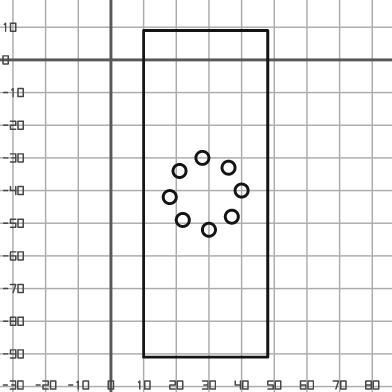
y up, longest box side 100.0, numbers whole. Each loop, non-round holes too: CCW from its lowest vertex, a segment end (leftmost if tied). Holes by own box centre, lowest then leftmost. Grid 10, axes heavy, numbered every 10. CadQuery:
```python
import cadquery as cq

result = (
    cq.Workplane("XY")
    .moveTo(10.0, -91.0)
    .lineTo(48.0, -91.0)
    .lineTo(48.0, 9.0)
    .lineTo(10.0, 9.0)
    .close()
    .moveTo(30.0, -52.0)
    .circle(2.0)
    .moveTo(22.0, -49.0)
    .circle(2.0)
    .moveTo(37.0, -48.0)
    .circle(2.0)
    .moveTo(18.0, -42.0)
    .circle(2.0)
    .moveTo(40.0, -40.0)
    .circle(2.0)
    .moveTo(21.0, -34.0)
    .circle(2.0)
    .moveTo(36.0, -33.0)
    .circle(2.0)
    .moveTo(28.0, -30.0)
    .circle(2.0)
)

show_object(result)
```